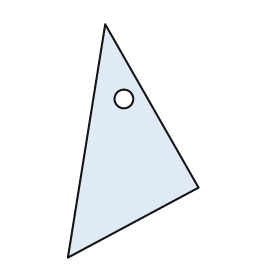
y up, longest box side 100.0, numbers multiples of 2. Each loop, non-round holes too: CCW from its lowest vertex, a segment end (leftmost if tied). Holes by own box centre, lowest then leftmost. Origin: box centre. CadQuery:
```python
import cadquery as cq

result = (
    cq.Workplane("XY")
    .moveTo(-28.0, -50.0)
    .lineTo(28.0, -20.0)
    .lineTo(-12.0, 50.0)
    .close()
    .moveTo(-4.0, 18.0)
    .circle(4.0)
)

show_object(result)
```